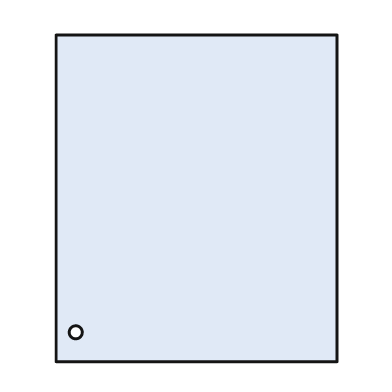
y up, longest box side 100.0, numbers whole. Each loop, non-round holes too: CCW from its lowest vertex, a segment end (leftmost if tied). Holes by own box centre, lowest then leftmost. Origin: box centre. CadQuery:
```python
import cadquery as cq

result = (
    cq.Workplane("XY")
    .moveTo(-43.0, -50.0)
    .lineTo(43.0, -50.0)
    .lineTo(43.0, 50.0)
    .lineTo(-43.0, 50.0)
    .close()
    .moveTo(-37.0, -41.0)
    .circle(2.0)
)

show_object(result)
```